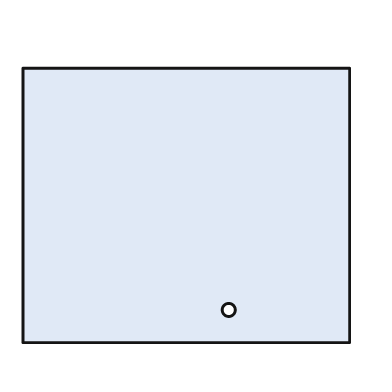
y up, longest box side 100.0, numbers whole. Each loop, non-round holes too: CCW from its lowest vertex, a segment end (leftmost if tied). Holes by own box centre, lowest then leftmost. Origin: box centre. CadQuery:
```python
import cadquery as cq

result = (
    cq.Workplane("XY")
    .moveTo(-50.0, -42.0)
    .lineTo(50.0, -42.0)
    .lineTo(50.0, 42.0)
    .lineTo(-50.0, 42.0)
    .close()
    .moveTo(13.0, -32.0)
    .circle(2.0)
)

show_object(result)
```